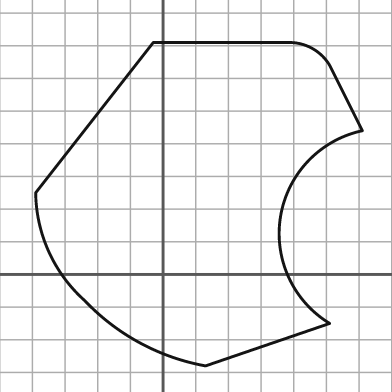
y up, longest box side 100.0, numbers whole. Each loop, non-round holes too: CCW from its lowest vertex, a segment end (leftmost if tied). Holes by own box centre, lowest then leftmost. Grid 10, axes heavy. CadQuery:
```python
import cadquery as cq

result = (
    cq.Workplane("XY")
    .moveTo(13.0, -28.0)
    .lineTo(51.0, -15.0)
    .threePointArc((36.0, 18.0), (61.0, 44.0))
    .lineTo(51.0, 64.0)
    .threePointArc((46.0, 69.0), (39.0, 71.0))
    .lineTo(-3.0, 71.0)
    .lineTo(-39.0, 25.0)
    .threePointArc((-35.0, 7.0), (-24.0, -8.0))
    .threePointArc((-7.0, -21.0), (13.0, -28.0))
    .close()
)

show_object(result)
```